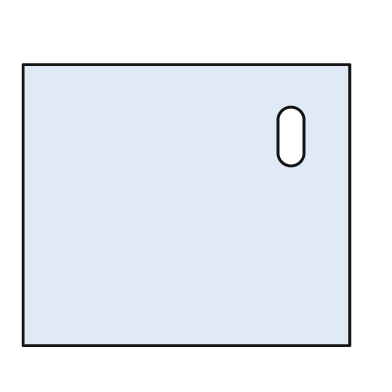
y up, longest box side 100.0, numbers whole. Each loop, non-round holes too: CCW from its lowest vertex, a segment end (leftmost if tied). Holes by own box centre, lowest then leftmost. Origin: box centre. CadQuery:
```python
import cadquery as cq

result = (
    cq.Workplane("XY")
    .moveTo(-50.0, -43.0)
    .lineTo(50.0, -43.0)
    .lineTo(50.0, 43.0)
    .lineTo(-50.0, 43.0)
    .close()
    .moveTo(28.0, 16.0)
    .threePointArc((32.0, 12.0), (36.0, 16.0))
    .lineTo(36.0, 26.0)
    .threePointArc((32.0, 30.0), (28.0, 26.0))
    .close()
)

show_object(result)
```